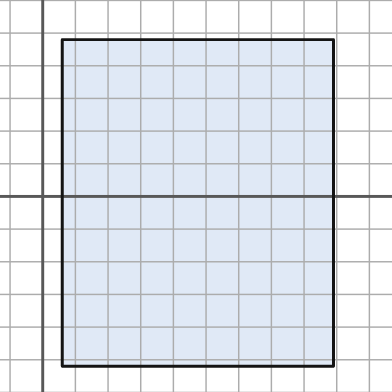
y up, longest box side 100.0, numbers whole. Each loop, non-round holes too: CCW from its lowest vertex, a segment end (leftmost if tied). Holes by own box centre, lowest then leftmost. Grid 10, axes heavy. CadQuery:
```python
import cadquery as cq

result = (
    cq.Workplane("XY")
    .moveTo(6.0, -52.0)
    .lineTo(89.0, -52.0)
    .lineTo(89.0, 48.0)
    .lineTo(6.0, 48.0)
    .close()
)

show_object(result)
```